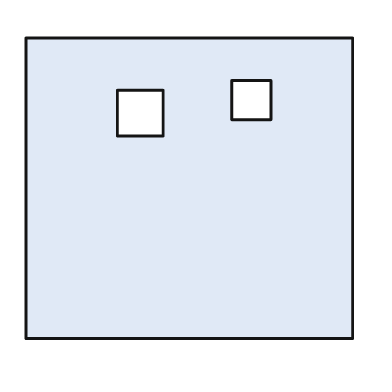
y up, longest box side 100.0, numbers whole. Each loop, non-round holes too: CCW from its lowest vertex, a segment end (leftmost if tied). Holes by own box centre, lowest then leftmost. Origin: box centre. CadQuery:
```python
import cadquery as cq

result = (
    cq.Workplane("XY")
    .moveTo(-50.0, -46.0)
    .lineTo(50.0, -46.0)
    .lineTo(50.0, 46.0)
    .lineTo(-50.0, 46.0)
    .close()
    .moveTo(-22.0, 16.0)
    .lineTo(-8.0, 16.0)
    .lineTo(-8.0, 30.0)
    .lineTo(-22.0, 30.0)
    .close()
    .moveTo(13.0, 21.0)
    .lineTo(25.0, 21.0)
    .lineTo(25.0, 33.0)
    .lineTo(13.0, 33.0)
    .close()
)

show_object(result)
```